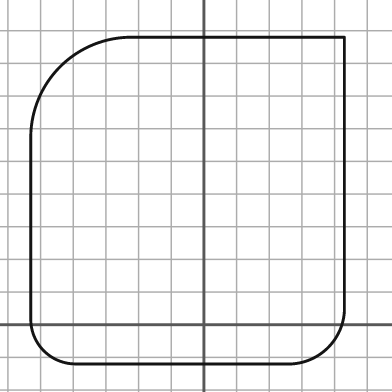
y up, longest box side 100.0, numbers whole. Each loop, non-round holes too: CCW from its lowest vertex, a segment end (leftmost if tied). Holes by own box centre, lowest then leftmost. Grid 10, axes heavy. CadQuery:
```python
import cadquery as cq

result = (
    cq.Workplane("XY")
    .moveTo(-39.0, -12.0)
    .lineTo(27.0, -12.0)
    .threePointArc((38.0, -7.0), (43.0, 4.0))
    .lineTo(43.0, 88.0)
    .lineTo(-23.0, 88.0)
    .threePointArc((-44.0, 79.0), (-53.0, 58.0))
    .lineTo(-53.0, 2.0)
    .threePointArc((-49.0, -8.0), (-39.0, -12.0))
    .close()
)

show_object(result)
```